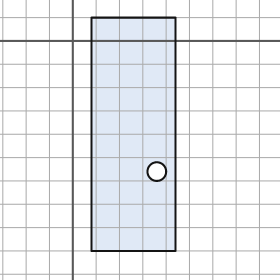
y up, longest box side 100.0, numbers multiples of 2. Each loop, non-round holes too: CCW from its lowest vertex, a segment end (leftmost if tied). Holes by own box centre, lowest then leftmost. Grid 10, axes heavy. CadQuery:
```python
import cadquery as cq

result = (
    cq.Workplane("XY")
    .moveTo(8.0, -90.0)
    .lineTo(44.0, -90.0)
    .lineTo(44.0, 10.0)
    .lineTo(8.0, 10.0)
    .close()
    .moveTo(36.0, -56.0)
    .circle(4.0)
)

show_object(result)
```